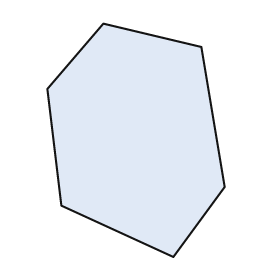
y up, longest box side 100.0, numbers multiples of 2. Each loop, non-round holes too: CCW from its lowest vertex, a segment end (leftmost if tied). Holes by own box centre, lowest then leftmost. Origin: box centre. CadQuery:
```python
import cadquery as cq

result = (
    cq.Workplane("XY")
    .moveTo(16.0, -50.0)
    .lineTo(38.0, -20.0)
    .lineTo(28.0, 40.0)
    .lineTo(-14.0, 50.0)
    .lineTo(-38.0, 22.0)
    .lineTo(-32.0, -28.0)
    .close()
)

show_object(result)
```